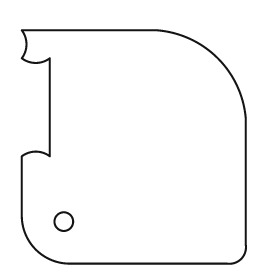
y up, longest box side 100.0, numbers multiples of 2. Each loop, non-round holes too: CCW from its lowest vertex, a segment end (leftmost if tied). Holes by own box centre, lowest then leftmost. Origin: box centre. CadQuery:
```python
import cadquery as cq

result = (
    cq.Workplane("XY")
    .moveTo(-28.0, -50.0)
    .lineTo(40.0, -50.0)
    .threePointArc((46.0, -48.0), (48.0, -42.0))
    .lineTo(48.0, 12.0)
    .threePointArc((36.0, 38.0), (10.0, 50.0))
    .lineTo(-48.0, 50.0)
    .threePointArc((-46.0, 44.0), (-48.0, 38.0))
    .threePointArc((-42.0, 36.0), (-36.0, 38.0))
    .lineTo(-36.0, -4.0)
    .threePointArc((-42.0, -2.0), (-48.0, -4.0))
    .lineTo(-48.0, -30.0)
    .threePointArc((-42.0, -44.0), (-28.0, -50.0))
    .close()
    .moveTo(-30.0, -32.0)
    .circle(4.0)
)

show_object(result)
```